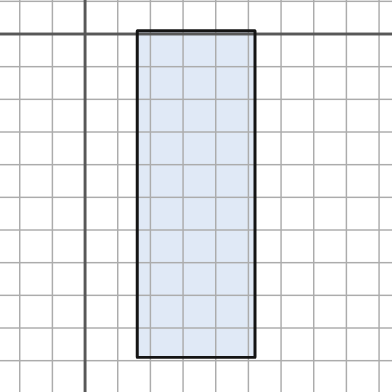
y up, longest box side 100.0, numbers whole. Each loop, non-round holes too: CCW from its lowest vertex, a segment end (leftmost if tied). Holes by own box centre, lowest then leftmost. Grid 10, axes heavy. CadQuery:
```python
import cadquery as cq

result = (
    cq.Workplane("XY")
    .moveTo(16.0, -99.0)
    .lineTo(52.0, -99.0)
    .lineTo(52.0, 1.0)
    .lineTo(16.0, 1.0)
    .close()
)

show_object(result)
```